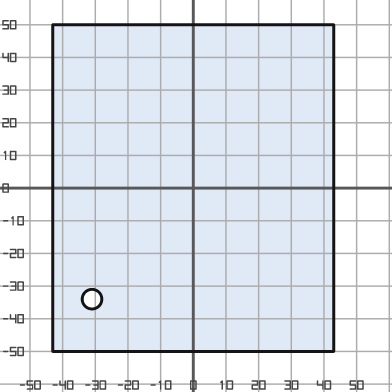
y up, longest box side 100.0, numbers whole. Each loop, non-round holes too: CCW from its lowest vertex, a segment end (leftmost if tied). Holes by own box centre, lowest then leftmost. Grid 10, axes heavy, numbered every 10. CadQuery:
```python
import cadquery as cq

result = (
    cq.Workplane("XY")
    .moveTo(-43.0, -50.0)
    .lineTo(43.0, -50.0)
    .lineTo(43.0, 50.0)
    .lineTo(-43.0, 50.0)
    .close()
    .moveTo(-31.0, -34.0)
    .circle(3.0)
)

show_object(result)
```